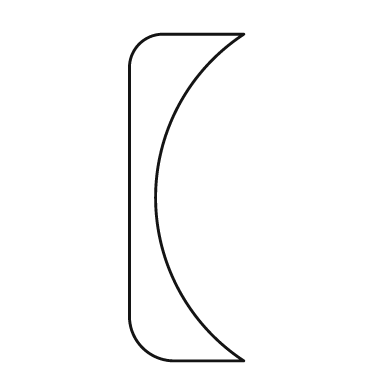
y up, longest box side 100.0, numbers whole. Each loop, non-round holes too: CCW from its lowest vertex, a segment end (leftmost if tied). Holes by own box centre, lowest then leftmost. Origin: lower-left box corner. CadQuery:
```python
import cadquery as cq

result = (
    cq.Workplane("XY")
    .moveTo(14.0, 0.0)
    .lineTo(35.0, 0.0)
    .threePointArc((8.0, 50.0), (35.0, 100.0))
    .lineTo(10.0, 100.0)
    .threePointArc((3.0, 97.0), (0.0, 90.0))
    .lineTo(0.0, 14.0)
    .threePointArc((4.0, 4.0), (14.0, 0.0))
    .close()
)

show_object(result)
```